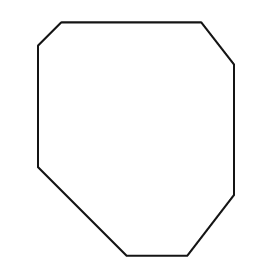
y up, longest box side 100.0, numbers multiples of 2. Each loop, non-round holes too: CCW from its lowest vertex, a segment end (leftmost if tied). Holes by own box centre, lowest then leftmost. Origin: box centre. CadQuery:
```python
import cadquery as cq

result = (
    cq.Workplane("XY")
    .moveTo(-4.0, -50.0)
    .lineTo(22.0, -50.0)
    .lineTo(42.0, -24.0)
    .lineTo(42.0, 32.0)
    .lineTo(28.0, 50.0)
    .lineTo(-32.0, 50.0)
    .lineTo(-42.0, 40.0)
    .lineTo(-42.0, -12.0)
    .close()
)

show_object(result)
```